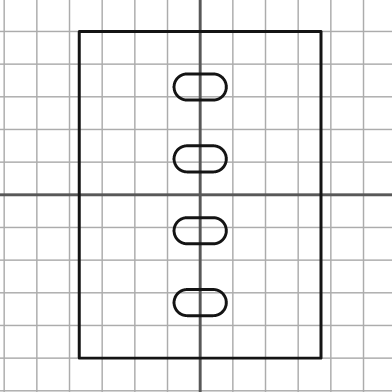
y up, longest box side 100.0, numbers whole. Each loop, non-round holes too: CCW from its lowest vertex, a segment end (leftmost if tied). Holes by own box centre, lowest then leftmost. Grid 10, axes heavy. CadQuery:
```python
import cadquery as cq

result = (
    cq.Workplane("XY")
    .moveTo(-37.0, -50.0)
    .lineTo(37.0, -50.0)
    .lineTo(37.0, 50.0)
    .lineTo(-37.0, 50.0)
    .close()
    .moveTo(-4.0, -37.0)
    .lineTo(4.0, -37.0)
    .threePointArc((8.0, -33.0), (4.0, -29.0))
    .lineTo(-4.0, -29.0)
    .threePointArc((-8.0, -33.0), (-4.0, -37.0))
    .close()
    .moveTo(-4.0, -15.0)
    .lineTo(4.0, -15.0)
    .threePointArc((8.0, -11.0), (4.0, -7.0))
    .lineTo(-4.0, -7.0)
    .threePointArc((-8.0, -11.0), (-4.0, -15.0))
    .close()
    .moveTo(-4.0, 7.0)
    .lineTo(4.0, 7.0)
    .threePointArc((8.0, 11.0), (4.0, 15.0))
    .lineTo(-4.0, 15.0)
    .threePointArc((-8.0, 11.0), (-4.0, 7.0))
    .close()
    .moveTo(-4.0, 29.0)
    .lineTo(4.0, 29.0)
    .threePointArc((8.0, 33.0), (4.0, 37.0))
    .lineTo(-4.0, 37.0)
    .threePointArc((-8.0, 33.0), (-4.0, 29.0))
    .close()
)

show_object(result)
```